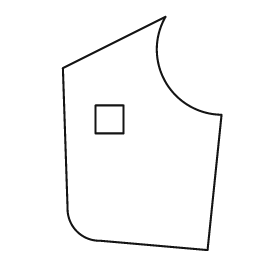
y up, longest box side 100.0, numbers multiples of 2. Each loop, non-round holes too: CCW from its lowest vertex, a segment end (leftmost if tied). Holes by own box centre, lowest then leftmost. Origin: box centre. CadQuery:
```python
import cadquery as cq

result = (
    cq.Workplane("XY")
    .moveTo(28.0, -50.0)
    .lineTo(34.0, 8.0)
    .threePointArc((10.0, 22.0), (10.0, 50.0))
    .lineTo(-34.0, 28.0)
    .lineTo(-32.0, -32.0)
    .threePointArc((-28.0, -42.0), (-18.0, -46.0))
    .close()
    .moveTo(-20.0, 0.0)
    .lineTo(-8.0, 0.0)
    .lineTo(-8.0, 12.0)
    .lineTo(-20.0, 12.0)
    .close()
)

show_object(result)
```